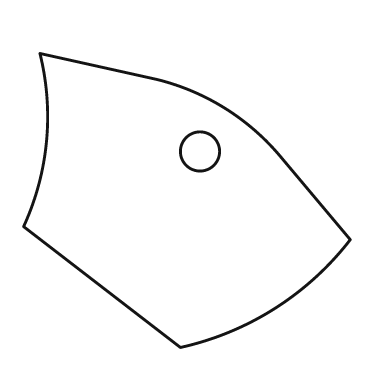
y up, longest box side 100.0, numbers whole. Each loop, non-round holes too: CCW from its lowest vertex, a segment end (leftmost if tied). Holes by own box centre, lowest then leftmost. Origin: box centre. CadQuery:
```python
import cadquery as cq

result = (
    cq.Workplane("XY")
    .moveTo(-2.0, -45.0)
    .threePointArc((27.0, -33.0), (50.0, -12.0))
    .lineTo(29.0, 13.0)
    .threePointArc((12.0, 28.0), (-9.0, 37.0))
    .lineTo(-45.0, 45.0)
    .threePointArc((-43.0, 18.0), (-50.0, -8.0))
    .close()
    .moveTo(4.0, 15.0)
    .circle(6.0)
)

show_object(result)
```